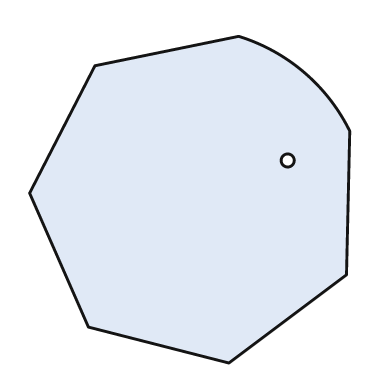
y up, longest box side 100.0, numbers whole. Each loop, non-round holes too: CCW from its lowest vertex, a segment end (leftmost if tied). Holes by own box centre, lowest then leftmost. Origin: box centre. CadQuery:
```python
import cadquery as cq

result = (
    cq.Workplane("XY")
    .moveTo(12.0, -50.0)
    .lineTo(48.0, -23.0)
    .lineTo(49.0, 21.0)
    .threePointArc((35.0, 39.0), (15.0, 50.0))
    .lineTo(-29.0, 41.0)
    .lineTo(-49.0, 2.0)
    .lineTo(-31.0, -39.0)
    .close()
    .moveTo(30.0, 12.0)
    .circle(2.0)
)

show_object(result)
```